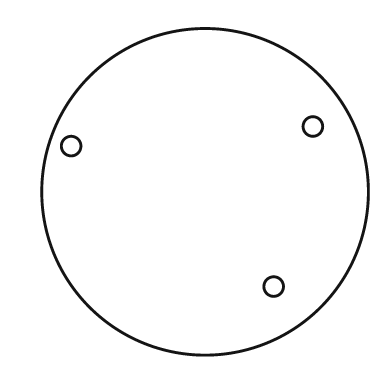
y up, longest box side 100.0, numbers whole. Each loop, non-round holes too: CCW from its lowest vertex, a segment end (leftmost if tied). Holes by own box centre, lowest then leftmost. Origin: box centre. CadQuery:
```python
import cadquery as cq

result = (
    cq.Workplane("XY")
    .moveTo(0.0, 0.0)
    .circle(50.0)
    .moveTo(21.0, -29.0)
    .circle(3.0)
    .moveTo(-41.0, 14.0)
    .circle(3.0)
    .moveTo(33.0, 20.0)
    .circle(3.0)
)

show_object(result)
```